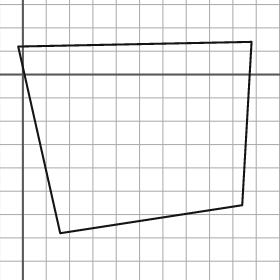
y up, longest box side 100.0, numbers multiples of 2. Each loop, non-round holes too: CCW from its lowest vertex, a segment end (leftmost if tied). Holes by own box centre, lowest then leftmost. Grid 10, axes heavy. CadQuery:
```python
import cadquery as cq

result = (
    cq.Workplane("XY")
    .moveTo(16.0, -68.0)
    .lineTo(94.0, -56.0)
    .lineTo(98.0, 14.0)
    .lineTo(-2.0, 12.0)
    .close()
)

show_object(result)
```